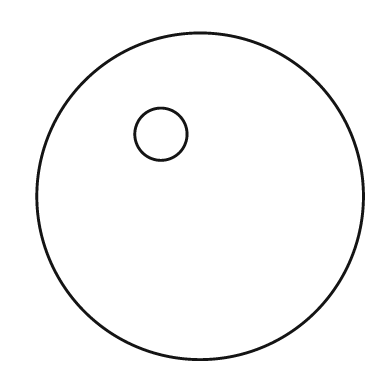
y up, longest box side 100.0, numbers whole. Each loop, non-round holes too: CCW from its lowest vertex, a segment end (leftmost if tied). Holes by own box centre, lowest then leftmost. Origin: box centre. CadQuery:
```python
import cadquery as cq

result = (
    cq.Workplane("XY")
    .moveTo(0.0, 0.0)
    .circle(50.0)
    .moveTo(-12.0, 19.0)
    .circle(8.0)
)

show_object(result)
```